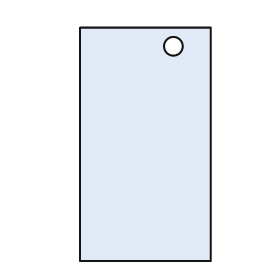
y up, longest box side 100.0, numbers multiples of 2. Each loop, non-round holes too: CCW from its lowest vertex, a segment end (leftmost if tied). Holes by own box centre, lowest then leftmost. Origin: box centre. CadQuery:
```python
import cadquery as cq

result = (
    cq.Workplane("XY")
    .moveTo(-28.0, -50.0)
    .lineTo(28.0, -50.0)
    .lineTo(28.0, 50.0)
    .lineTo(-28.0, 50.0)
    .close()
    .moveTo(12.0, 42.0)
    .circle(4.0)
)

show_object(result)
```